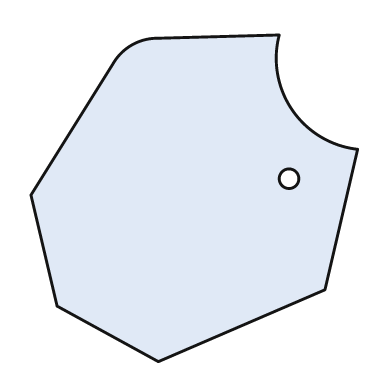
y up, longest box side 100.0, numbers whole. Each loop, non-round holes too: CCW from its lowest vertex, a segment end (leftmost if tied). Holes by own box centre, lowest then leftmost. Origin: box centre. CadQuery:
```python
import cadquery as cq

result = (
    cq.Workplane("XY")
    .moveTo(-11.0, -50.0)
    .lineTo(40.0, -28.0)
    .lineTo(50.0, 15.0)
    .threePointArc((30.0, 27.0), (26.0, 50.0))
    .lineTo(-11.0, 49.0)
    .threePointArc((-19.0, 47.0), (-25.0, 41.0))
    .lineTo(-50.0, 1.0)
    .lineTo(-42.0, -33.0)
    .close()
    .moveTo(29.0, 6.0)
    .circle(3.0)
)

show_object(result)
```